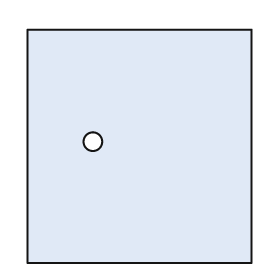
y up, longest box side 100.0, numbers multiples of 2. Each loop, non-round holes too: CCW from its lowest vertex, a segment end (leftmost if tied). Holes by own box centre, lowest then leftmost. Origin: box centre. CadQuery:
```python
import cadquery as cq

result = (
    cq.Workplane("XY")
    .moveTo(-48.0, -50.0)
    .lineTo(48.0, -50.0)
    .lineTo(48.0, 50.0)
    .lineTo(-48.0, 50.0)
    .close()
    .moveTo(-20.0, 2.0)
    .circle(4.0)
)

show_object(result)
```